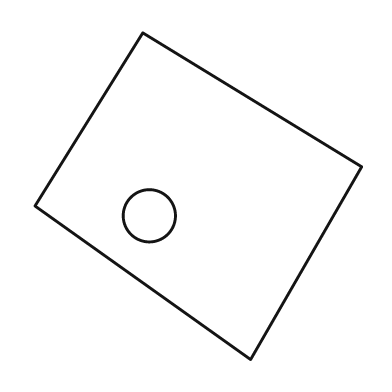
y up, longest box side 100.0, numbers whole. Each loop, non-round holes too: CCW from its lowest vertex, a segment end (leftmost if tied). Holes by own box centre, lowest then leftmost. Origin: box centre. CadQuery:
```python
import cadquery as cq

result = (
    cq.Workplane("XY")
    .moveTo(16.0, -50.0)
    .lineTo(50.0, 9.0)
    .lineTo(-17.0, 50.0)
    .lineTo(-50.0, -3.0)
    .close()
    .moveTo(-15.0, -6.0)
    .circle(8.0)
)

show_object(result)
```